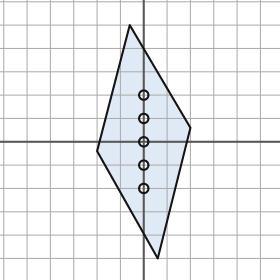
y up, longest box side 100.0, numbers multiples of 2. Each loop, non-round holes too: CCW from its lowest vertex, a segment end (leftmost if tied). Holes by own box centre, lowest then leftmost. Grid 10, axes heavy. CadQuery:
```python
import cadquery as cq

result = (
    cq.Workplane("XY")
    .moveTo(6.0, -50.0)
    .lineTo(20.0, 6.0)
    .lineTo(-6.0, 50.0)
    .lineTo(-20.0, -4.0)
    .close()
    .moveTo(0.0, -20.0)
    .circle(2.0)
    .moveTo(0.0, -10.0)
    .circle(2.0)
    .moveTo(0.0, 0.0)
    .circle(2.0)
    .moveTo(0.0, 10.0)
    .circle(2.0)
    .moveTo(0.0, 20.0)
    .circle(2.0)
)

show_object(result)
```